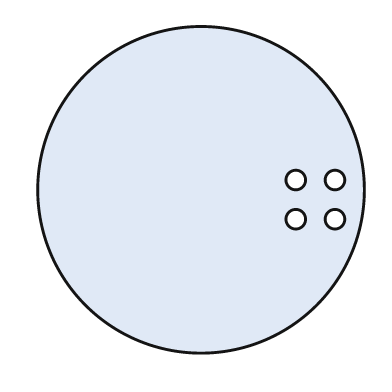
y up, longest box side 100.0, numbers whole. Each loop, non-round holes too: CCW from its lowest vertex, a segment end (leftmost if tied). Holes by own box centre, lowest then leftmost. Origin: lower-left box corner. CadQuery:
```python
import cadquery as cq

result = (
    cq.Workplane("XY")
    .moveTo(50.0, 50.0)
    .circle(50.0)
    .moveTo(79.0, 41.0)
    .circle(3.0)
    .moveTo(91.0, 41.0)
    .circle(3.0)
    .moveTo(79.0, 53.0)
    .circle(3.0)
    .moveTo(91.0, 53.0)
    .circle(3.0)
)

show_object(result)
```